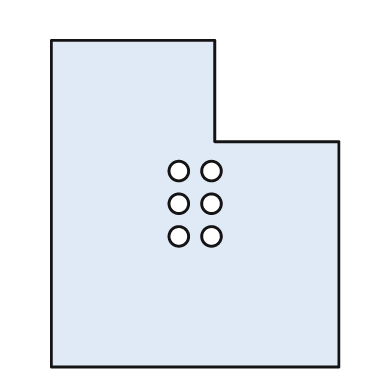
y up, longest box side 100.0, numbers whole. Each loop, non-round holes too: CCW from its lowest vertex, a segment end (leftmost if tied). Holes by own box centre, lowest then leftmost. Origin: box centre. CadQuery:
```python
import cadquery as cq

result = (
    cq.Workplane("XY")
    .moveTo(-44.0, -50.0)
    .lineTo(44.0, -50.0)
    .lineTo(44.0, 19.0)
    .lineTo(6.0, 19.0)
    .lineTo(6.0, 50.0)
    .lineTo(-44.0, 50.0)
    .close()
    .moveTo(-5.0, -10.0)
    .circle(3.0)
    .moveTo(5.0, -10.0)
    .circle(3.0)
    .moveTo(-5.0, 0.0)
    .circle(3.0)
    .moveTo(5.0, 0.0)
    .circle(3.0)
    .moveTo(-5.0, 10.0)
    .circle(3.0)
    .moveTo(5.0, 10.0)
    .circle(3.0)
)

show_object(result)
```